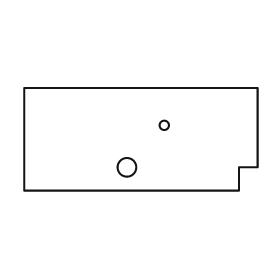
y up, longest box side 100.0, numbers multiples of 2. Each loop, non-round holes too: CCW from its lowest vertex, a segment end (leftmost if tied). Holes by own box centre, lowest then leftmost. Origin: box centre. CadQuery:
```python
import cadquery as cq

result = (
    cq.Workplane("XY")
    .moveTo(-50.0, -22.0)
    .lineTo(42.0, -22.0)
    .lineTo(42.0, -12.0)
    .lineTo(50.0, -12.0)
    .lineTo(50.0, 22.0)
    .lineTo(-50.0, 22.0)
    .close()
    .moveTo(-6.0, -12.0)
    .circle(4.0)
    .moveTo(10.0, 6.0)
    .circle(2.0)
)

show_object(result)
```